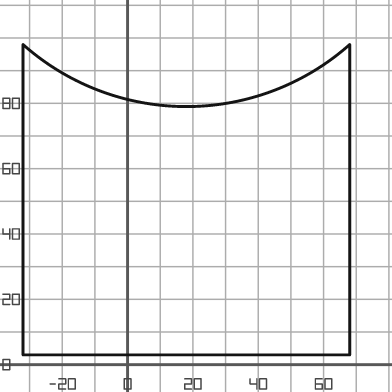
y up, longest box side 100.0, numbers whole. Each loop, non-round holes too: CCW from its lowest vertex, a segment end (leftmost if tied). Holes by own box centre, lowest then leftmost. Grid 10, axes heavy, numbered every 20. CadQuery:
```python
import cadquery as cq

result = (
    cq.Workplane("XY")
    .moveTo(-32.0, 3.0)
    .lineTo(68.0, 3.0)
    .lineTo(68.0, 98.0)
    .threePointArc((18.0, 79.0), (-32.0, 98.0))
    .close()
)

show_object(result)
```